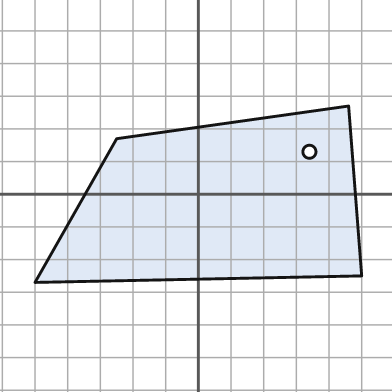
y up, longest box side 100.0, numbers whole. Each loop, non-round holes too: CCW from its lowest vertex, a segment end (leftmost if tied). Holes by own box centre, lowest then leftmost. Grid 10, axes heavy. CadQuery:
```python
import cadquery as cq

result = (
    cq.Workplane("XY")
    .moveTo(-50.0, -27.0)
    .lineTo(50.0, -25.0)
    .lineTo(46.0, 27.0)
    .lineTo(-25.0, 17.0)
    .close()
    .moveTo(34.0, 13.0)
    .circle(2.0)
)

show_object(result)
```